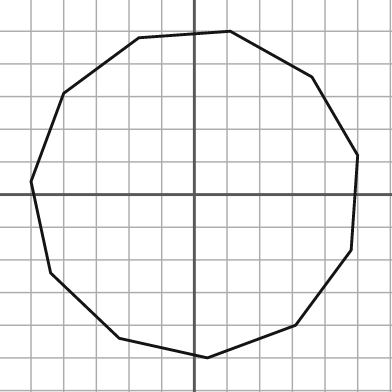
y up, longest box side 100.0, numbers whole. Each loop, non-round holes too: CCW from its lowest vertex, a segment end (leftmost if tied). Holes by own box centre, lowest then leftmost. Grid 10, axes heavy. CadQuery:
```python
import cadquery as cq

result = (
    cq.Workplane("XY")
    .moveTo(4.0, -50.0)
    .lineTo(31.0, -40.0)
    .lineTo(48.0, -17.0)
    .lineTo(50.0, 12.0)
    .lineTo(36.0, 36.0)
    .lineTo(11.0, 50.0)
    .lineTo(-17.0, 48.0)
    .lineTo(-40.0, 31.0)
    .lineTo(-50.0, 4.0)
    .lineTo(-44.0, -24.0)
    .lineTo(-23.0, -44.0)
    .close()
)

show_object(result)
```